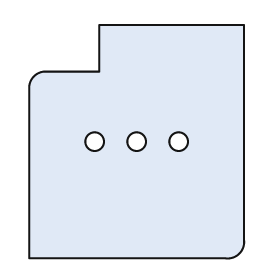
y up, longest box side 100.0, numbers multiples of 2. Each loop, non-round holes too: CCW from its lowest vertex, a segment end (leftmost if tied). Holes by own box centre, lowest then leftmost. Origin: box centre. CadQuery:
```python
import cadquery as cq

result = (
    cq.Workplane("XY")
    .moveTo(-46.0, -50.0)
    .lineTo(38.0, -50.0)
    .threePointArc((44.0, -48.0), (46.0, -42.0))
    .lineTo(46.0, 50.0)
    .lineTo(-16.0, 50.0)
    .lineTo(-16.0, 30.0)
    .lineTo(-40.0, 30.0)
    .threePointArc((-44.0, 28.0), (-46.0, 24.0))
    .close()
    .moveTo(-18.0, 0.0)
    .circle(4.0)
    .moveTo(0.0, 0.0)
    .circle(4.0)
    .moveTo(18.0, 0.0)
    .circle(4.0)
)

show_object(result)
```